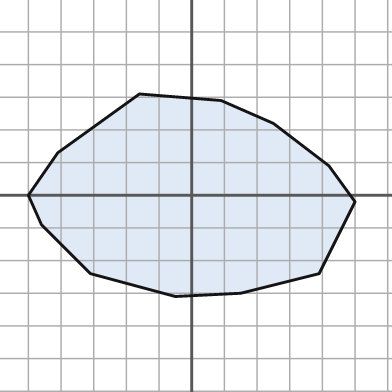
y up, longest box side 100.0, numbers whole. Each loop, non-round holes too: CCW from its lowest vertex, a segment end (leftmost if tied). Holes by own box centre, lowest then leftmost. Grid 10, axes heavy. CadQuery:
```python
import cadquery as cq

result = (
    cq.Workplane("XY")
    .moveTo(-5.0, -31.0)
    .lineTo(15.0, -30.0)
    .lineTo(39.0, -24.0)
    .lineTo(50.0, -2.0)
    .lineTo(42.0, 9.0)
    .lineTo(25.0, 22.0)
    .lineTo(9.0, 29.0)
    .lineTo(-16.0, 31.0)
    .lineTo(-41.0, 13.0)
    .lineTo(-50.0, 0.0)
    .lineTo(-46.0, -9.0)
    .lineTo(-31.0, -24.0)
    .close()
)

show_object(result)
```